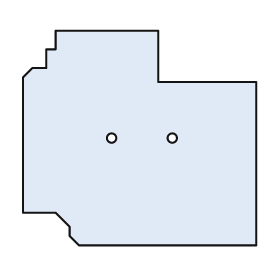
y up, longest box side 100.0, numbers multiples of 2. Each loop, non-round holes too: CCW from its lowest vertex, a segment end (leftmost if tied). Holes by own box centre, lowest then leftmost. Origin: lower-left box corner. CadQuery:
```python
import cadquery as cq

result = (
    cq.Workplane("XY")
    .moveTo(24.0, 0.0)
    .lineTo(100.0, 0.0)
    .lineTo(100.0, 70.0)
    .lineTo(58.0, 70.0)
    .lineTo(58.0, 92.0)
    .lineTo(14.0, 92.0)
    .lineTo(14.0, 84.0)
    .lineTo(10.0, 84.0)
    .lineTo(10.0, 76.0)
    .lineTo(4.0, 76.0)
    .lineTo(0.0, 72.0)
    .lineTo(0.0, 14.0)
    .lineTo(14.0, 14.0)
    .lineTo(20.0, 8.0)
    .lineTo(20.0, 4.0)
    .close()
    .moveTo(38.0, 46.0)
    .circle(2.0)
    .moveTo(64.0, 46.0)
    .circle(2.0)
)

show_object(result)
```